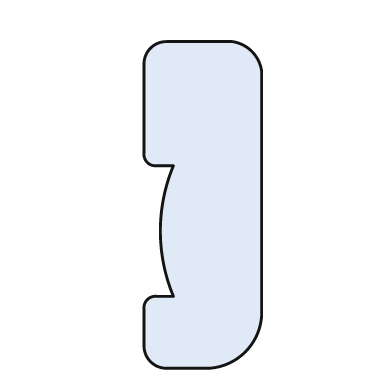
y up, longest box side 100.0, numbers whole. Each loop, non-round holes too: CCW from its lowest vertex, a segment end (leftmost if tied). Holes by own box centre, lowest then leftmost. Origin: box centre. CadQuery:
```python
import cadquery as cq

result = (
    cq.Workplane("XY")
    .moveTo(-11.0, -50.0)
    .lineTo(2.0, -50.0)
    .threePointArc((13.0, -45.0), (18.0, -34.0))
    .lineTo(18.0, 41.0)
    .threePointArc((15.0, 47.0), (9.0, 50.0))
    .lineTo(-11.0, 50.0)
    .threePointArc((-16.0, 48.0), (-18.0, 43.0))
    .lineTo(-18.0, 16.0)
    .threePointArc((-17.0, 13.0), (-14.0, 12.0))
    .lineTo(-9.0, 12.0)
    .threePointArc((-13.0, -8.0), (-9.0, -28.0))
    .lineTo(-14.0, -28.0)
    .threePointArc((-17.0, -29.0), (-18.0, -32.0))
    .lineTo(-18.0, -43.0)
    .threePointArc((-16.0, -48.0), (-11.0, -50.0))
    .close()
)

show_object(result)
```